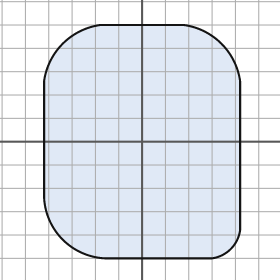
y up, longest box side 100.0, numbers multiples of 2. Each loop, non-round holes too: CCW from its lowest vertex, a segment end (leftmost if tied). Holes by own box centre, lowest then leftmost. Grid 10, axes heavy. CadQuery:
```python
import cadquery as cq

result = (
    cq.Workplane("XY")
    .moveTo(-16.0, -50.0)
    .lineTo(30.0, -50.0)
    .threePointArc((38.0, -46.0), (42.0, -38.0))
    .lineTo(42.0, 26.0)
    .threePointArc((34.0, 42.0), (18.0, 50.0))
    .lineTo(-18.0, 50.0)
    .threePointArc((-34.0, 42.0), (-42.0, 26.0))
    .lineTo(-42.0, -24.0)
    .threePointArc((-34.0, -42.0), (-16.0, -50.0))
    .close()
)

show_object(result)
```